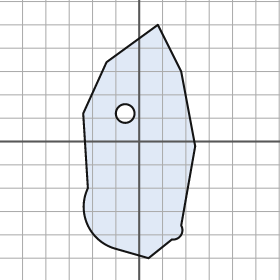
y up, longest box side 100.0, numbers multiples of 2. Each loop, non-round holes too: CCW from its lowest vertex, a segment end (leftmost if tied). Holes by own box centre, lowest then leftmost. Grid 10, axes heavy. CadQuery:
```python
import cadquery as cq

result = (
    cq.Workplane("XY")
    .moveTo(4.0, -50.0)
    .lineTo(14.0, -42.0)
    .threePointArc((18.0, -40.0), (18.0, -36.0))
    .lineTo(24.0, -2.0)
    .lineTo(18.0, 30.0)
    .lineTo(8.0, 50.0)
    .lineTo(-14.0, 34.0)
    .lineTo(-24.0, 12.0)
    .lineTo(-22.0, -20.0)
    .threePointArc((-22.0, -36.0), (-10.0, -46.0))
    .close()
    .moveTo(-6.0, 12.0)
    .circle(4.0)
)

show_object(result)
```